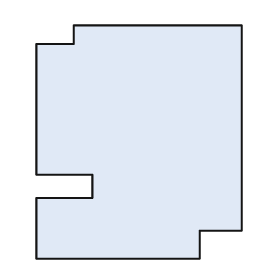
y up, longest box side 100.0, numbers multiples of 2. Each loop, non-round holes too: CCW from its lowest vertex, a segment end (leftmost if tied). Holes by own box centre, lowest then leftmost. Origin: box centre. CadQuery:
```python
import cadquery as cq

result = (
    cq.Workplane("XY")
    .moveTo(-44.0, -50.0)
    .lineTo(26.0, -50.0)
    .lineTo(26.0, -38.0)
    .lineTo(44.0, -38.0)
    .lineTo(44.0, 50.0)
    .lineTo(-28.0, 50.0)
    .lineTo(-28.0, 42.0)
    .lineTo(-44.0, 42.0)
    .lineTo(-44.0, -14.0)
    .lineTo(-20.0, -14.0)
    .lineTo(-20.0, -24.0)
    .lineTo(-44.0, -24.0)
    .close()
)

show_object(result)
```